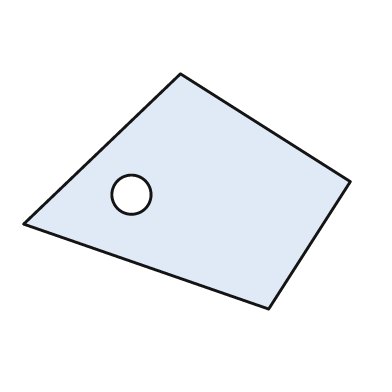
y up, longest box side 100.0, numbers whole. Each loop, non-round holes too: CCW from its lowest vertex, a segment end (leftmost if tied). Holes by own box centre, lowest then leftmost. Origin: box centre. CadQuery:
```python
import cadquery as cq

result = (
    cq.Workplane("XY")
    .moveTo(25.0, -36.0)
    .lineTo(50.0, 3.0)
    .lineTo(-2.0, 36.0)
    .lineTo(-50.0, -10.0)
    .close()
    .moveTo(-17.0, -1.0)
    .circle(6.0)
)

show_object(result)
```